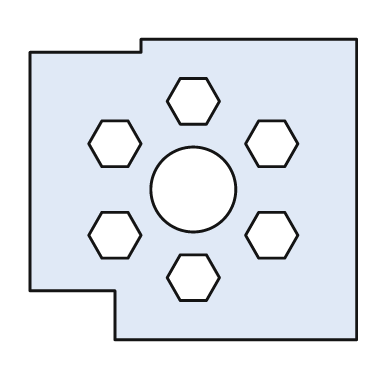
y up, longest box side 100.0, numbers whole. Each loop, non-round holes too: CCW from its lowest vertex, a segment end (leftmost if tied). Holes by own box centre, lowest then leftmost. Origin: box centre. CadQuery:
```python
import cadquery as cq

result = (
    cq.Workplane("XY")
    .moveTo(-24.0, -46.0)
    .lineTo(50.0, -46.0)
    .lineTo(50.0, 46.0)
    .lineTo(-16.0, 46.0)
    .lineTo(-16.0, 42.0)
    .lineTo(-50.0, 42.0)
    .lineTo(-50.0, -31.0)
    .lineTo(-24.0, -31.0)
    .close()
    .moveTo(-4.0, -34.0)
    .lineTo(4.0, -34.0)
    .lineTo(8.0, -27.0)
    .lineTo(4.0, -20.0)
    .lineTo(-4.0, -20.0)
    .lineTo(-8.0, -27.0)
    .close()
    .moveTo(-28.0, -21.0)
    .lineTo(-20.0, -21.0)
    .lineTo(-16.0, -14.0)
    .lineTo(-20.0, -7.0)
    .lineTo(-28.0, -7.0)
    .lineTo(-32.0, -14.0)
    .close()
    .moveTo(20.0, -21.0)
    .lineTo(28.0, -21.0)
    .lineTo(32.0, -14.0)
    .lineTo(28.0, -7.0)
    .lineTo(20.0, -7.0)
    .lineTo(16.0, -14.0)
    .close()
    .moveTo(0.0, 0.0)
    .circle(13.0)
    .moveTo(-28.0, 7.0)
    .lineTo(-20.0, 7.0)
    .lineTo(-16.0, 14.0)
    .lineTo(-20.0, 21.0)
    .lineTo(-28.0, 21.0)
    .lineTo(-32.0, 14.0)
    .close()
    .moveTo(20.0, 7.0)
    .lineTo(28.0, 7.0)
    .lineTo(32.0, 14.0)
    .lineTo(28.0, 21.0)
    .lineTo(20.0, 21.0)
    .lineTo(16.0, 14.0)
    .close()
    .moveTo(-4.0, 20.0)
    .lineTo(4.0, 20.0)
    .lineTo(8.0, 27.0)
    .lineTo(4.0, 34.0)
    .lineTo(-4.0, 34.0)
    .lineTo(-8.0, 27.0)
    .close()
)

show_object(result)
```